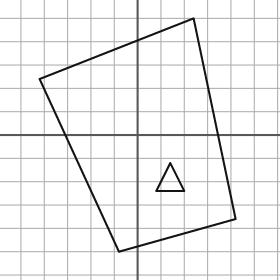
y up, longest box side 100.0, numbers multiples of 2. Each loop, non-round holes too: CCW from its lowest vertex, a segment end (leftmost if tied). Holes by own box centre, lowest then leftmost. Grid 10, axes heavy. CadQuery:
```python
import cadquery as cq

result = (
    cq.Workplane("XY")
    .moveTo(-8.0, -50.0)
    .lineTo(42.0, -36.0)
    .lineTo(24.0, 50.0)
    .lineTo(-42.0, 24.0)
    .close()
    .moveTo(8.0, -24.0)
    .lineTo(20.0, -24.0)
    .lineTo(14.0, -12.0)
    .close()
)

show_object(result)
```